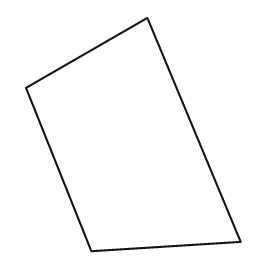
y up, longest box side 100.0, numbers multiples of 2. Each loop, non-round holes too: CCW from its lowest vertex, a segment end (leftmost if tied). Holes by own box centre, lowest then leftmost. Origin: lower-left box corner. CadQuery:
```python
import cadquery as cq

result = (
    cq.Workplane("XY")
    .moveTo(28.0, 0.0)
    .lineTo(92.0, 4.0)
    .lineTo(52.0, 100.0)
    .lineTo(0.0, 70.0)
    .close()
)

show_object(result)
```